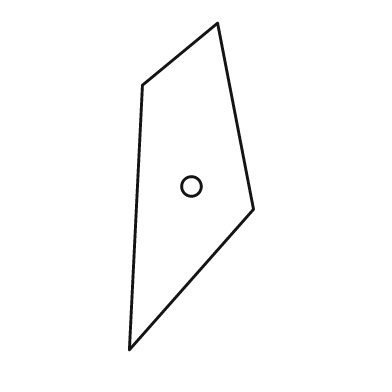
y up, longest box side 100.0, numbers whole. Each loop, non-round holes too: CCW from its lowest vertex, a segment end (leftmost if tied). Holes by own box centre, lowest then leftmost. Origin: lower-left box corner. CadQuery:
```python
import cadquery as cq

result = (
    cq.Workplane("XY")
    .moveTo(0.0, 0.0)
    .lineTo(38.0, 43.0)
    .lineTo(27.0, 100.0)
    .lineTo(4.0, 81.0)
    .close()
    .moveTo(19.0, 50.0)
    .circle(3.0)
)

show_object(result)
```